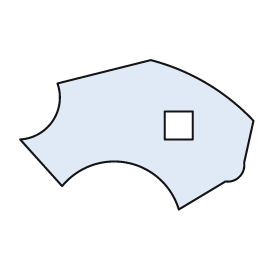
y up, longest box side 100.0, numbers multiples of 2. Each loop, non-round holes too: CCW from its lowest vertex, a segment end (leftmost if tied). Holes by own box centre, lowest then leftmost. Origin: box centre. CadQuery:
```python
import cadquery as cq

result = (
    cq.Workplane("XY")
    .moveTo(18.0, -32.0)
    .lineTo(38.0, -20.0)
    .threePointArc((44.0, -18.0), (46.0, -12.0))
    .lineTo(50.0, 6.0)
    .threePointArc((30.0, 22.0), (6.0, 32.0))
    .lineTo(-34.0, 22.0)
    .threePointArc((-36.0, 6.0), (-50.0, -2.0))
    .lineTo(-32.0, -22.0)
    .threePointArc((-4.0, -12.0), (18.0, -32.0))
    .close()
    .moveTo(12.0, -2.0)
    .lineTo(24.0, -2.0)
    .lineTo(24.0, 10.0)
    .lineTo(12.0, 10.0)
    .close()
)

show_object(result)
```